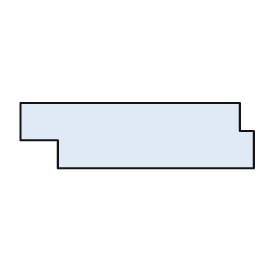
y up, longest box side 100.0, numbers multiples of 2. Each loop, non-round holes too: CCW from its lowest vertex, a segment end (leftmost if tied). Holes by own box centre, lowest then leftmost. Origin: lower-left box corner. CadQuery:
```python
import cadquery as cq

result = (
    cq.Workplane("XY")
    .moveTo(16.0, 0.0)
    .lineTo(100.0, 0.0)
    .lineTo(100.0, 16.0)
    .lineTo(94.0, 16.0)
    .lineTo(94.0, 28.0)
    .lineTo(0.0, 28.0)
    .lineTo(0.0, 12.0)
    .lineTo(16.0, 12.0)
    .close()
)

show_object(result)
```